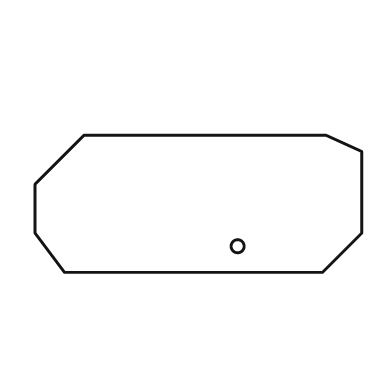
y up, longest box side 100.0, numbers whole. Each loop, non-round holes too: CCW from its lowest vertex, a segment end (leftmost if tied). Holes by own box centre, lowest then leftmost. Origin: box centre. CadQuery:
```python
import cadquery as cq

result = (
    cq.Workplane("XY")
    .moveTo(-41.0, -21.0)
    .lineTo(38.0, -21.0)
    .lineTo(50.0, -9.0)
    .lineTo(50.0, 16.0)
    .lineTo(39.0, 21.0)
    .lineTo(-35.0, 21.0)
    .lineTo(-50.0, 6.0)
    .lineTo(-50.0, -9.0)
    .close()
    .moveTo(12.0, -13.0)
    .circle(2.0)
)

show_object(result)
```